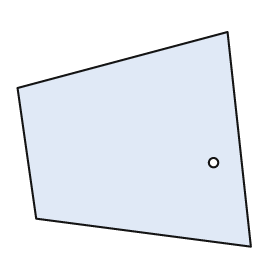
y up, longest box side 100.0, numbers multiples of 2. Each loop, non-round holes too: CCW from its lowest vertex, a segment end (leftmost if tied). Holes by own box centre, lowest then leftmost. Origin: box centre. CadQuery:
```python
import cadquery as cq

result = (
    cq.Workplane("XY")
    .moveTo(50.0, -46.0)
    .lineTo(40.0, 46.0)
    .lineTo(-50.0, 22.0)
    .lineTo(-42.0, -34.0)
    .close()
    .moveTo(34.0, -10.0)
    .circle(2.0)
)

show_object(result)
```